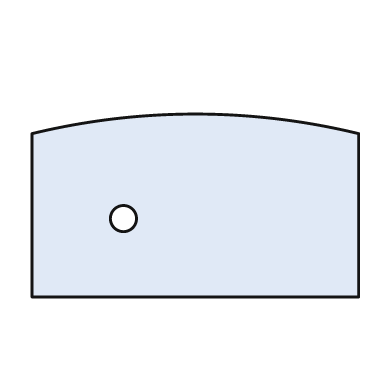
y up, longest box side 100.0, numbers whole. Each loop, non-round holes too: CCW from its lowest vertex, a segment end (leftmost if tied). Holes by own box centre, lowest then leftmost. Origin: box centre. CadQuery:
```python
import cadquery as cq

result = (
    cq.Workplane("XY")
    .moveTo(-50.0, -28.0)
    .lineTo(50.0, -28.0)
    .lineTo(50.0, 22.0)
    .threePointArc((0.0, 28.0), (-50.0, 22.0))
    .close()
    .moveTo(-22.0, -4.0)
    .circle(4.0)
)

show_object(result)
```